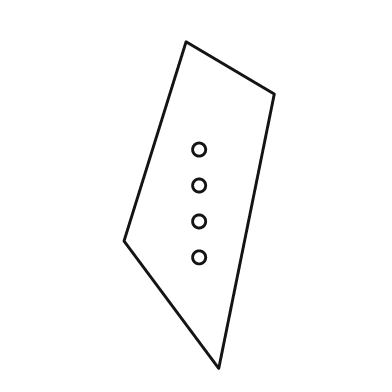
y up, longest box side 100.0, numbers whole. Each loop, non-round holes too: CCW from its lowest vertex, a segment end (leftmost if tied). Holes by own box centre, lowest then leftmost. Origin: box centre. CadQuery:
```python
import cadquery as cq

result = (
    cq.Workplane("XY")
    .moveTo(6.0, -50.0)
    .lineTo(23.0, 34.0)
    .lineTo(-4.0, 50.0)
    .lineTo(-23.0, -11.0)
    .close()
    .moveTo(0.0, -16.0)
    .circle(2.0)
    .moveTo(0.0, -5.0)
    .circle(2.0)
    .moveTo(0.0, 6.0)
    .circle(2.0)
    .moveTo(0.0, 17.0)
    .circle(2.0)
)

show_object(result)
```